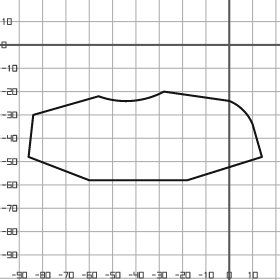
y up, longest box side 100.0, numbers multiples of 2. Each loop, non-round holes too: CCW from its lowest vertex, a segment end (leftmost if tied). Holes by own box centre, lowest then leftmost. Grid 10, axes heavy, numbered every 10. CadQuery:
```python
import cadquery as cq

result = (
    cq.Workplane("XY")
    .moveTo(-60.0, -58.0)
    .lineTo(-18.0, -58.0)
    .lineTo(14.0, -48.0)
    .lineTo(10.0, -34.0)
    .threePointArc((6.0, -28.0), (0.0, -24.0))
    .lineTo(-28.0, -20.0)
    .threePointArc((-42.0, -24.0), (-56.0, -22.0))
    .lineTo(-84.0, -30.0)
    .lineTo(-86.0, -48.0)
    .close()
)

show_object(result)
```